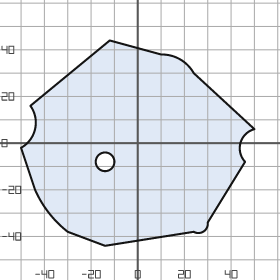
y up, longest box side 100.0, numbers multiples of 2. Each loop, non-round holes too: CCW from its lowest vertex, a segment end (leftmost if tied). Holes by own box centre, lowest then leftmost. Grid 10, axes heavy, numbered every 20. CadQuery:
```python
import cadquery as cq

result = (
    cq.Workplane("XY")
    .moveTo(-14.0, -44.0)
    .lineTo(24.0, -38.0)
    .threePointArc((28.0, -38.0), (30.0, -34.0))
    .lineTo(46.0, -8.0)
    .threePointArc((44.0, 0.0), (50.0, 6.0))
    .lineTo(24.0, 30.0)
    .threePointArc((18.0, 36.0), (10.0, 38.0))
    .lineTo(-12.0, 44.0)
    .lineTo(-46.0, 16.0)
    .threePointArc((-44.0, 6.0), (-50.0, -2.0))
    .lineTo(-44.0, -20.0)
    .threePointArc((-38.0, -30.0), (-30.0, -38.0))
    .close()
    .moveTo(-14.0, -8.0)
    .circle(4.0)
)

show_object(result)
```